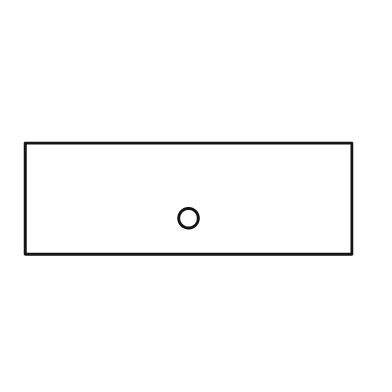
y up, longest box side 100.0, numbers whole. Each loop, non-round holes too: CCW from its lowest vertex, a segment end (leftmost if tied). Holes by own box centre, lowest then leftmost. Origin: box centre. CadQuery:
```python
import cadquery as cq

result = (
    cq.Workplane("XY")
    .moveTo(-50.0, -17.0)
    .lineTo(50.0, -17.0)
    .lineTo(50.0, 17.0)
    .lineTo(-50.0, 17.0)
    .close()
    .moveTo(0.0, -6.0)
    .circle(3.0)
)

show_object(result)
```